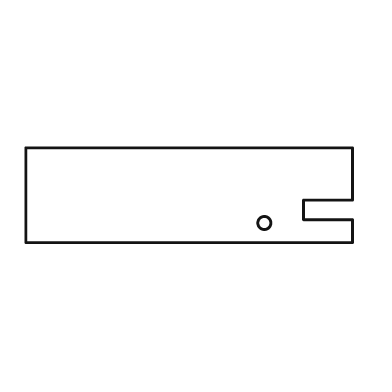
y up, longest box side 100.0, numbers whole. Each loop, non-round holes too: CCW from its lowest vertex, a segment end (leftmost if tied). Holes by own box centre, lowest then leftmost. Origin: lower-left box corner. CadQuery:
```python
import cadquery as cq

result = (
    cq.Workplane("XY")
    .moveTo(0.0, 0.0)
    .lineTo(100.0, 0.0)
    .lineTo(100.0, 7.0)
    .lineTo(85.0, 7.0)
    .lineTo(85.0, 13.0)
    .lineTo(100.0, 13.0)
    .lineTo(100.0, 29.0)
    .lineTo(0.0, 29.0)
    .close()
    .moveTo(73.0, 6.0)
    .circle(2.0)
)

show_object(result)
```